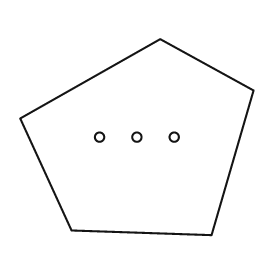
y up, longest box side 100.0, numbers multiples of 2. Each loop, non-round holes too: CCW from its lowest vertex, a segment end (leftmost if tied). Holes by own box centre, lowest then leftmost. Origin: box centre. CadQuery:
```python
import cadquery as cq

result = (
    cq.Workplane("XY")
    .moveTo(32.0, -42.0)
    .lineTo(50.0, 20.0)
    .lineTo(10.0, 42.0)
    .lineTo(-50.0, 8.0)
    .lineTo(-28.0, -40.0)
    .close()
    .moveTo(-16.0, 0.0)
    .circle(2.0)
    .moveTo(0.0, 0.0)
    .circle(2.0)
    .moveTo(16.0, 0.0)
    .circle(2.0)
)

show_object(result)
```